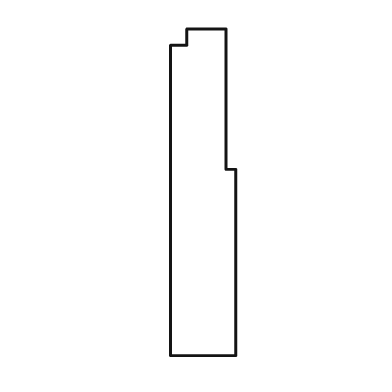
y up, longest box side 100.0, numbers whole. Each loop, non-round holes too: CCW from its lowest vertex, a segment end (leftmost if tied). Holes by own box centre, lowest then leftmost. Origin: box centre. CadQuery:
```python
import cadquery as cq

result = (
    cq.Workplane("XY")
    .moveTo(-10.0, -50.0)
    .lineTo(10.0, -50.0)
    .lineTo(10.0, 7.0)
    .lineTo(7.0, 7.0)
    .lineTo(7.0, 50.0)
    .lineTo(-5.0, 50.0)
    .lineTo(-5.0, 45.0)
    .lineTo(-10.0, 45.0)
    .close()
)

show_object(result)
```